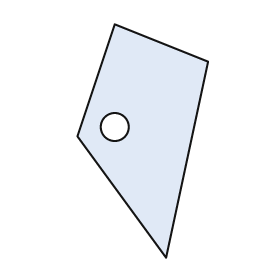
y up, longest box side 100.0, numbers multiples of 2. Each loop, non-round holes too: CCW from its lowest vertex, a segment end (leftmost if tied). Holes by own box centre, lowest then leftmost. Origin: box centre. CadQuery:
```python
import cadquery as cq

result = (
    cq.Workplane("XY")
    .moveTo(10.0, -50.0)
    .lineTo(28.0, 34.0)
    .lineTo(-12.0, 50.0)
    .lineTo(-28.0, 2.0)
    .close()
    .moveTo(-12.0, 6.0)
    .circle(6.0)
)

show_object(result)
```